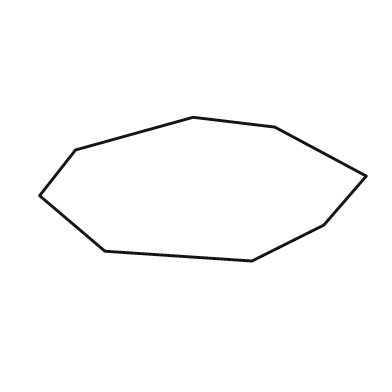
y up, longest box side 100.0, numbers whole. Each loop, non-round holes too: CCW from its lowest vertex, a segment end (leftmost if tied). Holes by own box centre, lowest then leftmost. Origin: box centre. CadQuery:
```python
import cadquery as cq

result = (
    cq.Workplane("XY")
    .moveTo(15.0, -22.0)
    .lineTo(37.0, -11.0)
    .lineTo(50.0, 4.0)
    .lineTo(22.0, 19.0)
    .lineTo(-3.0, 22.0)
    .lineTo(-39.0, 12.0)
    .lineTo(-50.0, -2.0)
    .lineTo(-30.0, -19.0)
    .close()
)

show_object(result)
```